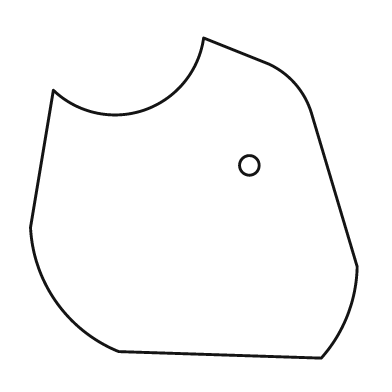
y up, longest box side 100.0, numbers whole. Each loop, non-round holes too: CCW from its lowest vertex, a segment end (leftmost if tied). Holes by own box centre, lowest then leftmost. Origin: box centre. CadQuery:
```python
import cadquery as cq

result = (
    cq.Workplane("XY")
    .moveTo(39.0, -49.0)
    .threePointArc((47.0, -36.0), (50.0, -21.0))
    .lineTo(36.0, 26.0)
    .threePointArc((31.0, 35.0), (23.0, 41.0))
    .lineTo(3.0, 49.0)
    .threePointArc((-15.0, 27.0), (-43.0, 33.0))
    .lineTo(-50.0, -9.0)
    .threePointArc((-42.0, -32.0), (-23.0, -47.0))
    .close()
    .moveTo(17.0, 10.0)
    .circle(3.0)
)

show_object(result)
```